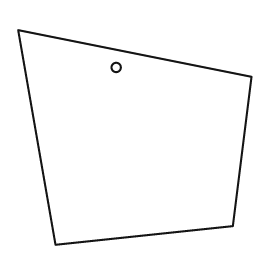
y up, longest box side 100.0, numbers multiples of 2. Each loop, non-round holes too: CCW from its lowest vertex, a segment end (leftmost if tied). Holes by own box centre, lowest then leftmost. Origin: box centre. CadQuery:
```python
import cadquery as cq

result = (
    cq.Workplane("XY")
    .moveTo(-34.0, -46.0)
    .lineTo(42.0, -38.0)
    .lineTo(50.0, 26.0)
    .lineTo(-50.0, 46.0)
    .close()
    .moveTo(-8.0, 30.0)
    .circle(2.0)
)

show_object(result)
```